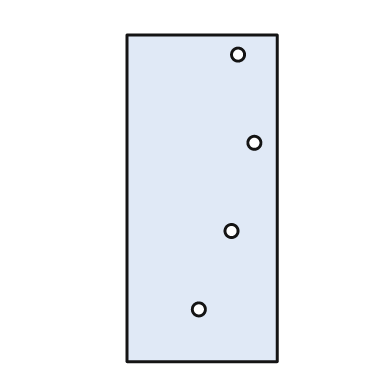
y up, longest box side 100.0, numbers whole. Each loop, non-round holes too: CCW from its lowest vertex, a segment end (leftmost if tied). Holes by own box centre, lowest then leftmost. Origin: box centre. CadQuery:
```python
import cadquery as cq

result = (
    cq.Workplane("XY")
    .moveTo(-23.0, -50.0)
    .lineTo(23.0, -50.0)
    .lineTo(23.0, 50.0)
    .lineTo(-23.0, 50.0)
    .close()
    .moveTo(-1.0, -34.0)
    .circle(2.0)
    .moveTo(9.0, -10.0)
    .circle(2.0)
    .moveTo(16.0, 17.0)
    .circle(2.0)
    .moveTo(11.0, 44.0)
    .circle(2.0)
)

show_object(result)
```